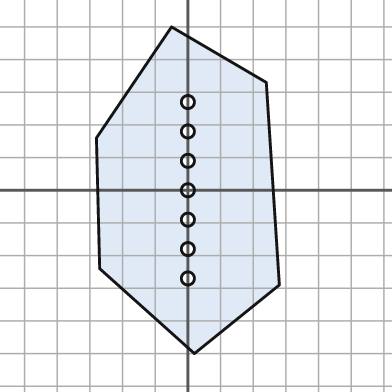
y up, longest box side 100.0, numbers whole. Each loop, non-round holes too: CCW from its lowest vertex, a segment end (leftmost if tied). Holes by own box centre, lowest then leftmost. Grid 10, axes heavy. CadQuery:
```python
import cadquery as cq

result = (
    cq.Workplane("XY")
    .moveTo(2.0, -50.0)
    .lineTo(28.0, -29.0)
    .lineTo(24.0, 33.0)
    .lineTo(-5.0, 50.0)
    .lineTo(-28.0, 16.0)
    .lineTo(-27.0, -24.0)
    .close()
    .moveTo(0.0, -27.0)
    .circle(2.0)
    .moveTo(0.0, -18.0)
    .circle(2.0)
    .moveTo(0.0, -9.0)
    .circle(2.0)
    .moveTo(0.0, 0.0)
    .circle(2.0)
    .moveTo(0.0, 9.0)
    .circle(2.0)
    .moveTo(0.0, 18.0)
    .circle(2.0)
    .moveTo(0.0, 27.0)
    .circle(2.0)
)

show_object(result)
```